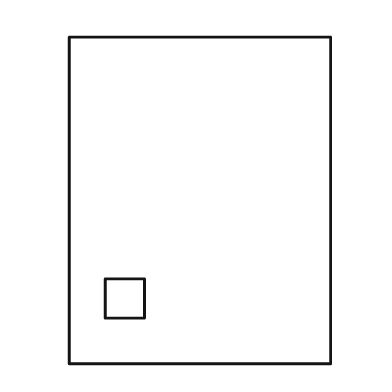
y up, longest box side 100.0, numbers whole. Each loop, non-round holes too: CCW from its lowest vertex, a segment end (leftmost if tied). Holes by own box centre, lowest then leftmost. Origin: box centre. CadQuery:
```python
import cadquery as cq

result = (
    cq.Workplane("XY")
    .moveTo(-40.0, -50.0)
    .lineTo(40.0, -50.0)
    .lineTo(40.0, 50.0)
    .lineTo(-40.0, 50.0)
    .close()
    .moveTo(-29.0, -36.0)
    .lineTo(-17.0, -36.0)
    .lineTo(-17.0, -24.0)
    .lineTo(-29.0, -24.0)
    .close()
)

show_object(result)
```